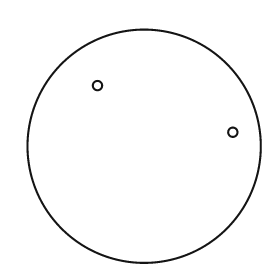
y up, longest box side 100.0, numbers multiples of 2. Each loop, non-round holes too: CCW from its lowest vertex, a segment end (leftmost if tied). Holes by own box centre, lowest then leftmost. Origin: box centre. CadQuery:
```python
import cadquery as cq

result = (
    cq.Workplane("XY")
    .moveTo(0.0, 0.0)
    .circle(50.0)
    .moveTo(38.0, 6.0)
    .circle(2.0)
    .moveTo(-20.0, 26.0)
    .circle(2.0)
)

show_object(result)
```